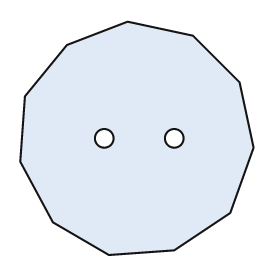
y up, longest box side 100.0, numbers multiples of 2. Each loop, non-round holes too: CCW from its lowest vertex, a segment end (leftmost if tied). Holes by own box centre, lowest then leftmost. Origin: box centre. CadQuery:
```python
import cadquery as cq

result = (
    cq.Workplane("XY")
    .moveTo(-12.0, -50.0)
    .lineTo(16.0, -48.0)
    .lineTo(40.0, -32.0)
    .lineTo(50.0, -4.0)
    .lineTo(44.0, 24.0)
    .lineTo(24.0, 44.0)
    .lineTo(-4.0, 50.0)
    .lineTo(-30.0, 40.0)
    .lineTo(-48.0, 18.0)
    .lineTo(-50.0, -10.0)
    .lineTo(-36.0, -36.0)
    .close()
    .moveTo(-14.0, 0.0)
    .circle(4.0)
    .moveTo(16.0, 0.0)
    .circle(4.0)
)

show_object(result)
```